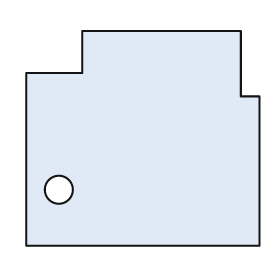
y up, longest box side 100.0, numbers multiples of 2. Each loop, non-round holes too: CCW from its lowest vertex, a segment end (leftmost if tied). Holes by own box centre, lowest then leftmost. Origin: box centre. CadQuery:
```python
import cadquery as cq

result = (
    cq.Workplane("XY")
    .moveTo(-50.0, -46.0)
    .lineTo(50.0, -46.0)
    .lineTo(50.0, 18.0)
    .lineTo(42.0, 18.0)
    .lineTo(42.0, 46.0)
    .lineTo(-26.0, 46.0)
    .lineTo(-26.0, 28.0)
    .lineTo(-50.0, 28.0)
    .close()
    .moveTo(-36.0, -22.0)
    .circle(6.0)
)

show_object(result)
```